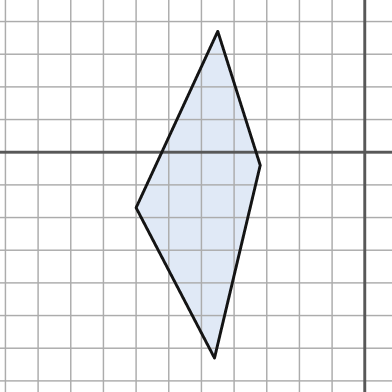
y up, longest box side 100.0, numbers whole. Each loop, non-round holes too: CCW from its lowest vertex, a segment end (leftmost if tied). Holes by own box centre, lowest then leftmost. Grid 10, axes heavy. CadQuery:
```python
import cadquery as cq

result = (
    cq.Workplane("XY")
    .moveTo(-46.0, -63.0)
    .lineTo(-32.0, -4.0)
    .lineTo(-45.0, 37.0)
    .lineTo(-70.0, -17.0)
    .close()
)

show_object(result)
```